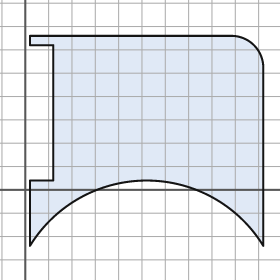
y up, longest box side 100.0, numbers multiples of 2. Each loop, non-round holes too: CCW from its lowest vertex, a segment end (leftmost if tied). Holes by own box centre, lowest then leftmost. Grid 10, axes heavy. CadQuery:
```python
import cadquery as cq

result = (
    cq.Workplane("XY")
    .moveTo(2.0, -24.0)
    .threePointArc((52.0, 4.0), (102.0, -24.0))
    .lineTo(102.0, 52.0)
    .threePointArc((98.0, 62.0), (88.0, 66.0))
    .lineTo(2.0, 66.0)
    .lineTo(2.0, 62.0)
    .lineTo(12.0, 62.0)
    .lineTo(12.0, 4.0)
    .lineTo(2.0, 4.0)
    .close()
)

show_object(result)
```